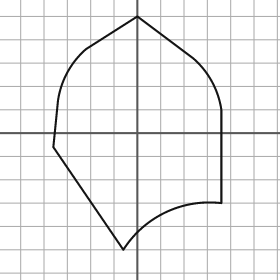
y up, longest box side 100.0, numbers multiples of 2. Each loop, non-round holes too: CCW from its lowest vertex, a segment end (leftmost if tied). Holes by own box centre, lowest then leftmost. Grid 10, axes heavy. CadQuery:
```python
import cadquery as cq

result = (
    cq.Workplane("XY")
    .moveTo(-6.0, -50.0)
    .threePointArc((12.0, -34.0), (36.0, -30.0))
    .lineTo(36.0, 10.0)
    .threePointArc((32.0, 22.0), (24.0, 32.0))
    .lineTo(0.0, 50.0)
    .lineTo(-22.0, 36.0)
    .threePointArc((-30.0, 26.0), (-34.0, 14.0))
    .lineTo(-36.0, -6.0)
    .close()
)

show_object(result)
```